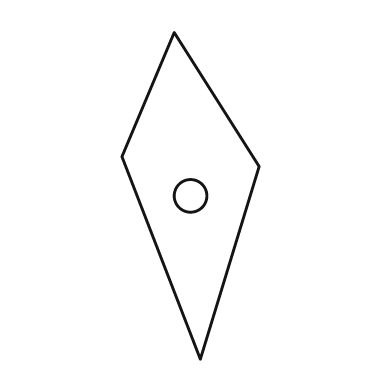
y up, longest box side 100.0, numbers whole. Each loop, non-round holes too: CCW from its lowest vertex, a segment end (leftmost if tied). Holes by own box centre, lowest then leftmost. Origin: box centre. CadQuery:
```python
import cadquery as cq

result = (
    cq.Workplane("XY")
    .moveTo(3.0, -50.0)
    .lineTo(21.0, 9.0)
    .lineTo(-5.0, 50.0)
    .lineTo(-21.0, 12.0)
    .close()
    .moveTo(0.0, 0.0)
    .circle(5.0)
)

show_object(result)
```